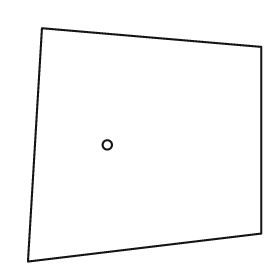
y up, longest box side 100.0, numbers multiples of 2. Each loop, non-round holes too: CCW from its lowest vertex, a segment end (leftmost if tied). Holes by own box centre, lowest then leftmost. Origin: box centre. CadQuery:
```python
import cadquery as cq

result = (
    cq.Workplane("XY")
    .moveTo(-50.0, -50.0)
    .lineTo(50.0, -38.0)
    .lineTo(50.0, 42.0)
    .lineTo(-44.0, 50.0)
    .close()
    .moveTo(-16.0, 0.0)
    .circle(2.0)
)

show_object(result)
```